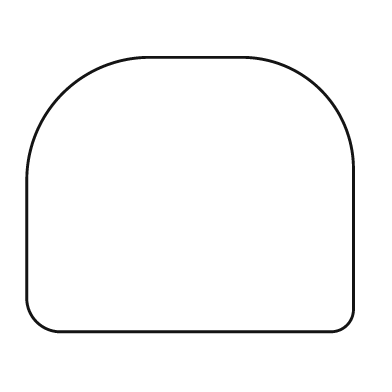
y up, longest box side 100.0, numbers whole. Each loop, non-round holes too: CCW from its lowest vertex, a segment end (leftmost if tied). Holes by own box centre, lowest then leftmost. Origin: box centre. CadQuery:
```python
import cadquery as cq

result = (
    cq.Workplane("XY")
    .moveTo(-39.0, -42.0)
    .lineTo(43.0, -42.0)
    .threePointArc((48.0, -40.0), (50.0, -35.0))
    .lineTo(50.0, 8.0)
    .threePointArc((40.0, 32.0), (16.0, 42.0))
    .lineTo(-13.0, 42.0)
    .threePointArc((-39.0, 31.0), (-50.0, 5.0))
    .lineTo(-50.0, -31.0)
    .threePointArc((-47.0, -39.0), (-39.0, -42.0))
    .close()
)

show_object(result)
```